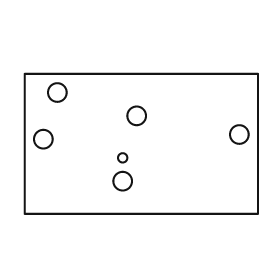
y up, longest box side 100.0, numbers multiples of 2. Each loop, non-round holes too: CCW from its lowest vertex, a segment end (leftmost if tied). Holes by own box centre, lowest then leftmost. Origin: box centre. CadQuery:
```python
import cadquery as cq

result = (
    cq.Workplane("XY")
    .moveTo(-50.0, -30.0)
    .lineTo(50.0, -30.0)
    .lineTo(50.0, 30.0)
    .lineTo(-50.0, 30.0)
    .close()
    .moveTo(-8.0, -16.0)
    .circle(4.0)
    .moveTo(-8.0, -6.0)
    .circle(2.0)
    .moveTo(-42.0, 2.0)
    .circle(4.0)
    .moveTo(42.0, 4.0)
    .circle(4.0)
    .moveTo(-2.0, 12.0)
    .circle(4.0)
    .moveTo(-36.0, 22.0)
    .circle(4.0)
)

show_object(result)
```